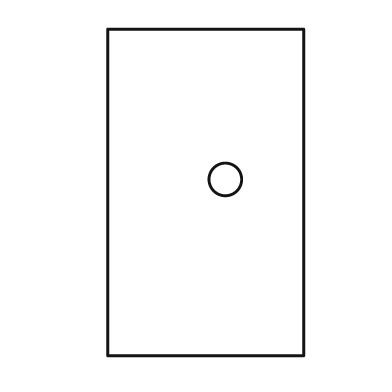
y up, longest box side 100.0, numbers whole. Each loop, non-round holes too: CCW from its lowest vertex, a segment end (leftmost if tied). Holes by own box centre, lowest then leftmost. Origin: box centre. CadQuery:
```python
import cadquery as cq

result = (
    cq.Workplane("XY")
    .moveTo(-30.0, -50.0)
    .lineTo(30.0, -50.0)
    .lineTo(30.0, 50.0)
    .lineTo(-30.0, 50.0)
    .close()
    .moveTo(6.0, 4.0)
    .circle(5.0)
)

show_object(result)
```